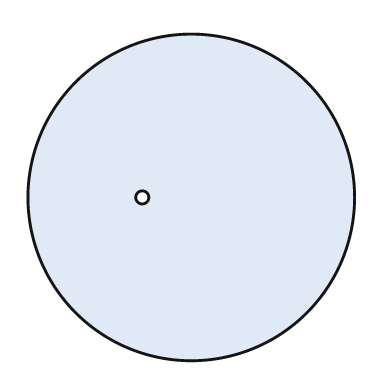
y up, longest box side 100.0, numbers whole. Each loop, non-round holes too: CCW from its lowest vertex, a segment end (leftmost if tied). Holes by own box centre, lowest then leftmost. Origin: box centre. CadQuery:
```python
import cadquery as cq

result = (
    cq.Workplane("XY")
    .moveTo(0.0, 0.0)
    .circle(50.0)
    .moveTo(-15.0, 0.0)
    .circle(2.0)
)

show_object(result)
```